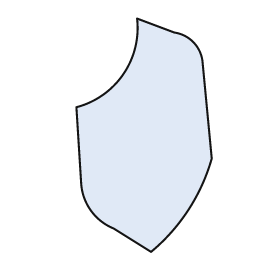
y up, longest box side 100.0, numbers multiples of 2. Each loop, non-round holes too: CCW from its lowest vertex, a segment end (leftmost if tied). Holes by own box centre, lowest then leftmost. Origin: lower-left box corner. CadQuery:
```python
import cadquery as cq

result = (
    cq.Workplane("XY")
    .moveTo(32.0, 0.0)
    .threePointArc((48.0, 18.0), (58.0, 40.0))
    .lineTo(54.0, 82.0)
    .threePointArc((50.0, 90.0), (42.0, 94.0))
    .lineTo(26.0, 100.0)
    .threePointArc((20.0, 76.0), (0.0, 62.0))
    .lineTo(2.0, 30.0)
    .threePointArc((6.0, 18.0), (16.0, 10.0))
    .close()
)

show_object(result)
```